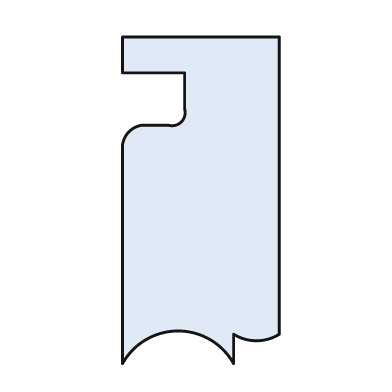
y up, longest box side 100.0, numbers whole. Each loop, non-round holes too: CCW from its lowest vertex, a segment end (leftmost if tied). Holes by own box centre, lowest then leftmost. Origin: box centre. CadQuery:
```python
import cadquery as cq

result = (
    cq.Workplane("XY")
    .moveTo(-24.0, -50.0)
    .threePointArc((-7.0, -40.0), (10.0, -50.0))
    .lineTo(10.0, -41.0)
    .threePointArc((17.0, -43.0), (24.0, -41.0))
    .lineTo(24.0, 50.0)
    .lineTo(-24.0, 50.0)
    .lineTo(-24.0, 39.0)
    .lineTo(-5.0, 39.0)
    .lineTo(-5.0, 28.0)
    .threePointArc((-6.0, 24.0), (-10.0, 23.0))
    .lineTo(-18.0, 23.0)
    .threePointArc((-22.0, 21.0), (-24.0, 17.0))
    .close()
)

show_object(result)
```